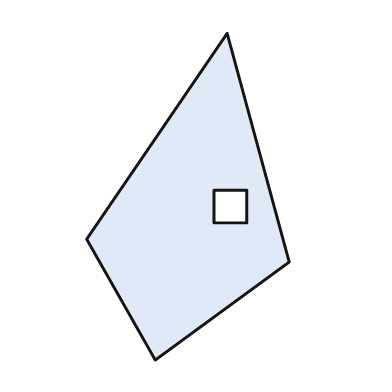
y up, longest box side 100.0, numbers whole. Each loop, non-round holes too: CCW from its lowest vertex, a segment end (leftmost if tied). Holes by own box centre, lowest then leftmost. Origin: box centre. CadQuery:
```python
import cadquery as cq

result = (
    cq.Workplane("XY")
    .moveTo(-10.0, -50.0)
    .lineTo(31.0, -20.0)
    .lineTo(12.0, 50.0)
    .lineTo(-31.0, -13.0)
    .close()
    .moveTo(8.0, -8.0)
    .lineTo(18.0, -8.0)
    .lineTo(18.0, 2.0)
    .lineTo(8.0, 2.0)
    .close()
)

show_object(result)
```